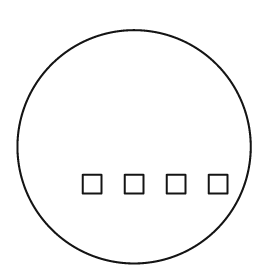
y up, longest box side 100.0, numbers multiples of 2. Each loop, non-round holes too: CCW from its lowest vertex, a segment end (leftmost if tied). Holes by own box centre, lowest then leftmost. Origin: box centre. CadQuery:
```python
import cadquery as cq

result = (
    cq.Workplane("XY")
    .moveTo(0.0, 0.0)
    .circle(50.0)
    .moveTo(-22.0, -20.0)
    .lineTo(-14.0, -20.0)
    .lineTo(-14.0, -12.0)
    .lineTo(-22.0, -12.0)
    .close()
    .moveTo(-4.0, -20.0)
    .lineTo(4.0, -20.0)
    .lineTo(4.0, -12.0)
    .lineTo(-4.0, -12.0)
    .close()
    .moveTo(14.0, -20.0)
    .lineTo(22.0, -20.0)
    .lineTo(22.0, -12.0)
    .lineTo(14.0, -12.0)
    .close()
    .moveTo(32.0, -20.0)
    .lineTo(40.0, -20.0)
    .lineTo(40.0, -12.0)
    .lineTo(32.0, -12.0)
    .close()
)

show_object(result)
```